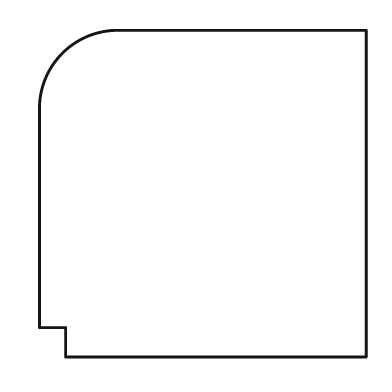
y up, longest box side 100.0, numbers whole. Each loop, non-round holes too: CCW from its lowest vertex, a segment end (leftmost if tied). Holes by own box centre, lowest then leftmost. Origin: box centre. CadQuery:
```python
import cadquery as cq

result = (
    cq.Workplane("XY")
    .moveTo(-42.0, -50.0)
    .lineTo(50.0, -50.0)
    .lineTo(50.0, 50.0)
    .lineTo(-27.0, 50.0)
    .threePointArc((-43.0, 43.0), (-50.0, 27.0))
    .lineTo(-50.0, -41.0)
    .lineTo(-42.0, -41.0)
    .close()
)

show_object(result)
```